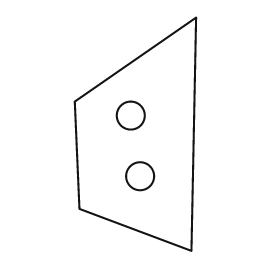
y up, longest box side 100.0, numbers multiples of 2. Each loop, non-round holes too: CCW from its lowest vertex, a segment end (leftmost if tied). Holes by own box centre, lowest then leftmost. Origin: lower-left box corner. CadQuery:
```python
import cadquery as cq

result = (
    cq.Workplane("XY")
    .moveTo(50.0, 0.0)
    .lineTo(52.0, 100.0)
    .lineTo(0.0, 64.0)
    .lineTo(2.0, 18.0)
    .close()
    .moveTo(28.0, 32.0)
    .circle(6.0)
    .moveTo(24.0, 58.0)
    .circle(6.0)
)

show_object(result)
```